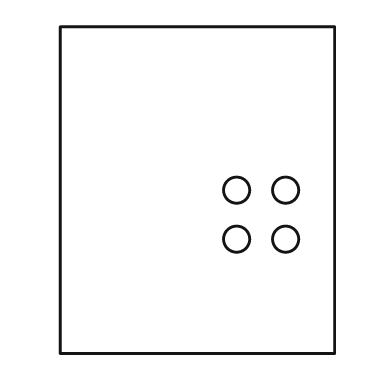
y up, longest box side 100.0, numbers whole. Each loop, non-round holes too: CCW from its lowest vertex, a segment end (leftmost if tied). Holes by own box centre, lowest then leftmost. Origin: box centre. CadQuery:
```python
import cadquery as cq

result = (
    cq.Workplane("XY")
    .moveTo(-42.0, -50.0)
    .lineTo(42.0, -50.0)
    .lineTo(42.0, 50.0)
    .lineTo(-42.0, 50.0)
    .close()
    .moveTo(12.0, -15.0)
    .circle(4.0)
    .moveTo(27.0, -15.0)
    .circle(4.0)
    .moveTo(12.0, 0.0)
    .circle(4.0)
    .moveTo(27.0, 0.0)
    .circle(4.0)
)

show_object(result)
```